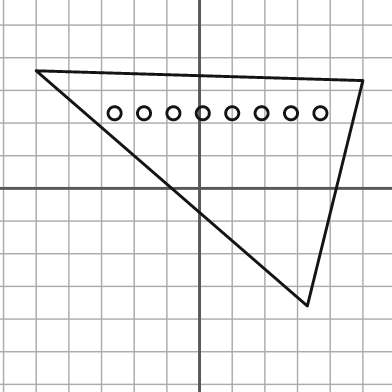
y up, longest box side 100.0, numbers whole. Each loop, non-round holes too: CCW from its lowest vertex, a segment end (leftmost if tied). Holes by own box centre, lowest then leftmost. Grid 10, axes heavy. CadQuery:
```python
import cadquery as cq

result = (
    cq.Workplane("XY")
    .moveTo(33.0, -36.0)
    .lineTo(50.0, 33.0)
    .lineTo(-50.0, 36.0)
    .close()
    .moveTo(-26.0, 23.0)
    .circle(2.0)
    .moveTo(-17.0, 23.0)
    .circle(2.0)
    .moveTo(-8.0, 23.0)
    .circle(2.0)
    .moveTo(1.0, 23.0)
    .circle(2.0)
    .moveTo(10.0, 23.0)
    .circle(2.0)
    .moveTo(19.0, 23.0)
    .circle(2.0)
    .moveTo(28.0, 23.0)
    .circle(2.0)
    .moveTo(37.0, 23.0)
    .circle(2.0)
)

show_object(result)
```